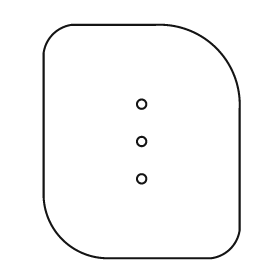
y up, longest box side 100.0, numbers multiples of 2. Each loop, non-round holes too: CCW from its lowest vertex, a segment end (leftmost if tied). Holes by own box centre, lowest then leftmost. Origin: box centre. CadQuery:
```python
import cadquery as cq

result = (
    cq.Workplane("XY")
    .moveTo(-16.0, -50.0)
    .lineTo(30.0, -50.0)
    .threePointArc((38.0, -46.0), (42.0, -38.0))
    .lineTo(42.0, 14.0)
    .threePointArc((32.0, 40.0), (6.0, 50.0))
    .lineTo(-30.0, 50.0)
    .threePointArc((-38.0, 46.0), (-42.0, 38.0))
    .lineTo(-42.0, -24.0)
    .threePointArc((-34.0, -42.0), (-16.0, -50.0))
    .close()
    .moveTo(0.0, -16.0)
    .circle(2.0)
    .moveTo(0.0, 0.0)
    .circle(2.0)
    .moveTo(0.0, 16.0)
    .circle(2.0)
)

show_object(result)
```